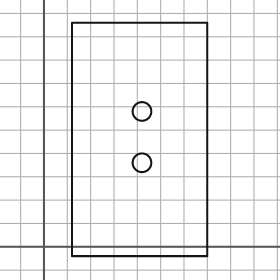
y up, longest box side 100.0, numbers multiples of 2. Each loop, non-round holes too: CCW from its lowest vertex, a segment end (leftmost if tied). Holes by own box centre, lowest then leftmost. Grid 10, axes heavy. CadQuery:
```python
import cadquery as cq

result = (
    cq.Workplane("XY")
    .moveTo(12.0, -4.0)
    .lineTo(70.0, -4.0)
    .lineTo(70.0, 96.0)
    .lineTo(12.0, 96.0)
    .close()
    .moveTo(42.0, 36.0)
    .circle(4.0)
    .moveTo(42.0, 58.0)
    .circle(4.0)
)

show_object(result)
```